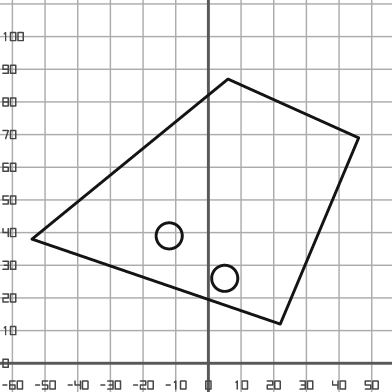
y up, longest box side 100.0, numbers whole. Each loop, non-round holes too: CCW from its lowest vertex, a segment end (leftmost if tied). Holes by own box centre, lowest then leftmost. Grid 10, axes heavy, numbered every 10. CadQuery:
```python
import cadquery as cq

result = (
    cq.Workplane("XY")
    .moveTo(22.0, 12.0)
    .lineTo(46.0, 69.0)
    .lineTo(6.0, 87.0)
    .lineTo(-54.0, 38.0)
    .close()
    .moveTo(5.0, 26.0)
    .circle(4.0)
    .moveTo(-12.0, 39.0)
    .circle(4.0)
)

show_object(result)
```